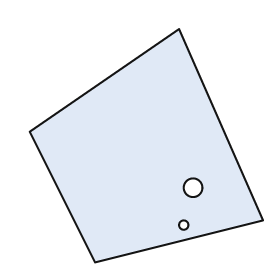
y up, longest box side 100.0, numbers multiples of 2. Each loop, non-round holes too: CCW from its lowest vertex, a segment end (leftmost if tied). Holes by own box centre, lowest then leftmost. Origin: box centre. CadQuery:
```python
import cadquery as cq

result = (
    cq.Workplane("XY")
    .moveTo(-22.0, -50.0)
    .lineTo(50.0, -32.0)
    .lineTo(14.0, 50.0)
    .lineTo(-50.0, 6.0)
    .close()
    .moveTo(16.0, -34.0)
    .circle(2.0)
    .moveTo(20.0, -18.0)
    .circle(4.0)
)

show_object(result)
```